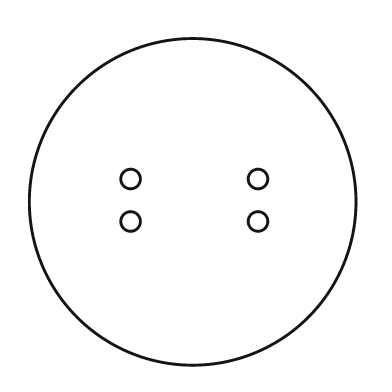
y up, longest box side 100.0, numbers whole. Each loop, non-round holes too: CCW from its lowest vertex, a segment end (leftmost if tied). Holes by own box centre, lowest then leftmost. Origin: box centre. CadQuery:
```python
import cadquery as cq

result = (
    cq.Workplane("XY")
    .moveTo(0.0, 0.0)
    .circle(50.0)
    .moveTo(-19.0, -6.0)
    .circle(3.0)
    .moveTo(20.0, -6.0)
    .circle(3.0)
    .moveTo(-19.0, 7.0)
    .circle(3.0)
    .moveTo(20.0, 7.0)
    .circle(3.0)
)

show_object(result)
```